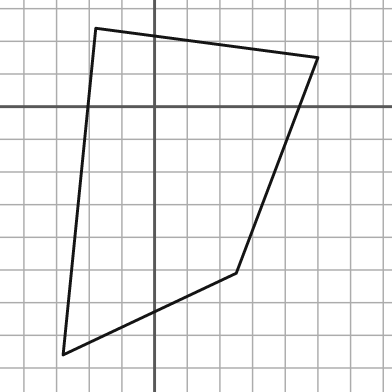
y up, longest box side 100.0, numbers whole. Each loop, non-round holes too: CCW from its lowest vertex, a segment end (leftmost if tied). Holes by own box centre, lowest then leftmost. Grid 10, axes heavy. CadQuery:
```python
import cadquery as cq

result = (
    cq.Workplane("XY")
    .moveTo(-28.0, -76.0)
    .lineTo(25.0, -51.0)
    .lineTo(50.0, 15.0)
    .lineTo(-18.0, 24.0)
    .close()
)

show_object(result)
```